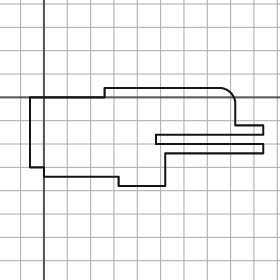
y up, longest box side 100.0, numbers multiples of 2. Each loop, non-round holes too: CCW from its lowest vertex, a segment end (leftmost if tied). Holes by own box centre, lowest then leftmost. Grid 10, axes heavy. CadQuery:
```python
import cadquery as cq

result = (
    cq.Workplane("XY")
    .moveTo(32.0, -38.0)
    .lineTo(52.0, -38.0)
    .lineTo(52.0, -24.0)
    .lineTo(94.0, -24.0)
    .lineTo(94.0, -20.0)
    .lineTo(48.0, -20.0)
    .lineTo(48.0, -16.0)
    .lineTo(94.0, -16.0)
    .lineTo(94.0, -12.0)
    .lineTo(82.0, -12.0)
    .lineTo(82.0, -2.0)
    .threePointArc((80.0, 2.0), (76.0, 4.0))
    .lineTo(26.0, 4.0)
    .lineTo(26.0, 0.0)
    .lineTo(-6.0, 0.0)
    .lineTo(-6.0, -30.0)
    .lineTo(0.0, -30.0)
    .lineTo(0.0, -34.0)
    .lineTo(32.0, -34.0)
    .close()
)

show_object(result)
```